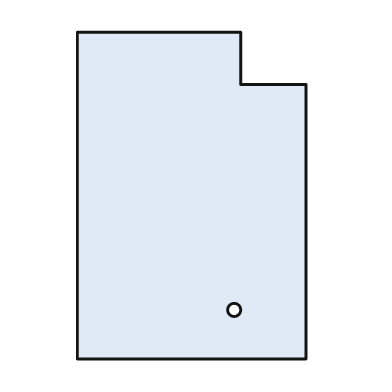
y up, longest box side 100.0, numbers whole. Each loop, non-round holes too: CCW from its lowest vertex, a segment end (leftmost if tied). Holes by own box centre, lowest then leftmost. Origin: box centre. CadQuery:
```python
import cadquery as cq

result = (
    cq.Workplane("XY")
    .moveTo(-35.0, -50.0)
    .lineTo(35.0, -50.0)
    .lineTo(35.0, 34.0)
    .lineTo(15.0, 34.0)
    .lineTo(15.0, 50.0)
    .lineTo(-35.0, 50.0)
    .close()
    .moveTo(13.0, -35.0)
    .circle(2.0)
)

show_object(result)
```